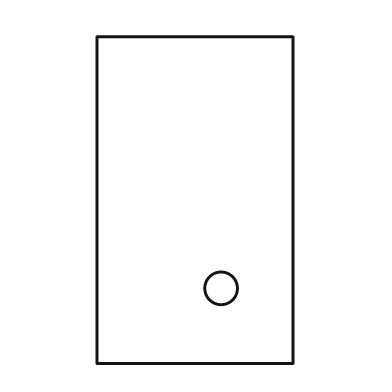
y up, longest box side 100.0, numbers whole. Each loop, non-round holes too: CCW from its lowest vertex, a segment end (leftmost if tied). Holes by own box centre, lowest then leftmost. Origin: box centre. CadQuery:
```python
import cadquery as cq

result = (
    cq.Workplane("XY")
    .moveTo(-30.0, -50.0)
    .lineTo(30.0, -50.0)
    .lineTo(30.0, 50.0)
    .lineTo(-30.0, 50.0)
    .close()
    .moveTo(8.0, -27.0)
    .circle(5.0)
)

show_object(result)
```